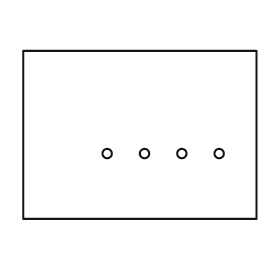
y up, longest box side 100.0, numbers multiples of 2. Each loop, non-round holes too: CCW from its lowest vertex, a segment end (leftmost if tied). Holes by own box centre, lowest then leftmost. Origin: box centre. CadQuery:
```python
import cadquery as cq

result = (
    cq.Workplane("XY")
    .moveTo(-50.0, -36.0)
    .lineTo(50.0, -36.0)
    .lineTo(50.0, 36.0)
    .lineTo(-50.0, 36.0)
    .close()
    .moveTo(-14.0, -8.0)
    .circle(2.0)
    .moveTo(2.0, -8.0)
    .circle(2.0)
    .moveTo(18.0, -8.0)
    .circle(2.0)
    .moveTo(34.0, -8.0)
    .circle(2.0)
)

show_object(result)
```